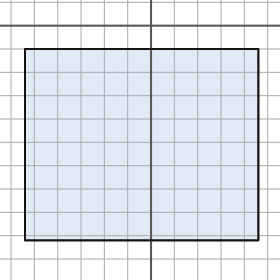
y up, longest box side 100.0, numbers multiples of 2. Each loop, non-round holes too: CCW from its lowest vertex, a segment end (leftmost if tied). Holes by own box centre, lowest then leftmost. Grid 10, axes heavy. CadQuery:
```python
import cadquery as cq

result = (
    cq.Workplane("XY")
    .moveTo(-54.0, -92.0)
    .lineTo(46.0, -92.0)
    .lineTo(46.0, -10.0)
    .lineTo(-54.0, -10.0)
    .close()
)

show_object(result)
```